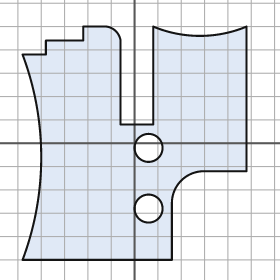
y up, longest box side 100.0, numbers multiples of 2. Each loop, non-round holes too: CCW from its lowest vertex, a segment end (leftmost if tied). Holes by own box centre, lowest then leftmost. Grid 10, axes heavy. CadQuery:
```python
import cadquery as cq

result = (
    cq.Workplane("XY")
    .moveTo(-48.0, -50.0)
    .lineTo(16.0, -50.0)
    .lineTo(16.0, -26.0)
    .threePointArc((20.0, -16.0), (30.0, -12.0))
    .lineTo(48.0, -12.0)
    .lineTo(48.0, 50.0)
    .threePointArc((28.0, 46.0), (8.0, 50.0))
    .lineTo(8.0, 8.0)
    .lineTo(-6.0, 8.0)
    .lineTo(-6.0, 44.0)
    .threePointArc((-8.0, 48.0), (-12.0, 50.0))
    .lineTo(-22.0, 50.0)
    .lineTo(-22.0, 44.0)
    .lineTo(-38.0, 44.0)
    .lineTo(-38.0, 38.0)
    .lineTo(-48.0, 38.0)
    .threePointArc((-40.0, -6.0), (-48.0, -50.0))
    .close()
    .moveTo(6.0, -28.0)
    .circle(6.0)
    .moveTo(6.0, -2.0)
    .circle(6.0)
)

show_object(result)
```